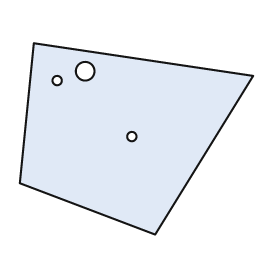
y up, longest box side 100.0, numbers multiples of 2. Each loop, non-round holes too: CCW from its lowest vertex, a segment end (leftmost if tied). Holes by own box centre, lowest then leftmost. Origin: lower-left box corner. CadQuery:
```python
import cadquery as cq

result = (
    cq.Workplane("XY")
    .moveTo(58.0, 0.0)
    .lineTo(100.0, 68.0)
    .lineTo(6.0, 82.0)
    .lineTo(0.0, 22.0)
    .close()
    .moveTo(48.0, 42.0)
    .circle(2.0)
    .moveTo(16.0, 66.0)
    .circle(2.0)
    .moveTo(28.0, 70.0)
    .circle(4.0)
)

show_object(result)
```